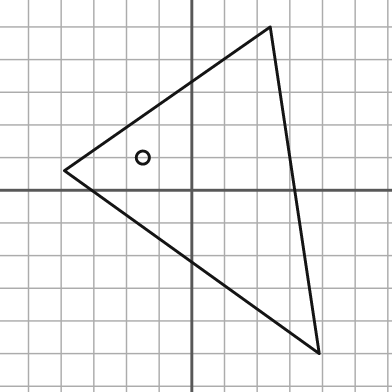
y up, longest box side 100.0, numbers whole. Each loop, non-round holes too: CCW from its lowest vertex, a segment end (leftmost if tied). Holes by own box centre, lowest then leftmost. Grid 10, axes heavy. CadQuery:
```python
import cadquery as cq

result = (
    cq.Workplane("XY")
    .moveTo(39.0, -50.0)
    .lineTo(24.0, 50.0)
    .lineTo(-39.0, 6.0)
    .close()
    .moveTo(-15.0, 10.0)
    .circle(2.0)
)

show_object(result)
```